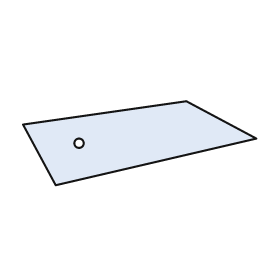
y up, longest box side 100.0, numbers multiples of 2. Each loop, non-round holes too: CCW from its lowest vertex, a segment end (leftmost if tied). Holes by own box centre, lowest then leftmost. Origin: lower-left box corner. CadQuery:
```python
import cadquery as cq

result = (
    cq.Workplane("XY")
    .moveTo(14.0, 0.0)
    .lineTo(100.0, 20.0)
    .lineTo(70.0, 36.0)
    .lineTo(0.0, 26.0)
    .close()
    .moveTo(24.0, 18.0)
    .circle(2.0)
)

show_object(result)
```